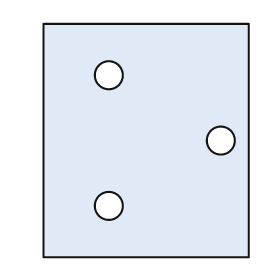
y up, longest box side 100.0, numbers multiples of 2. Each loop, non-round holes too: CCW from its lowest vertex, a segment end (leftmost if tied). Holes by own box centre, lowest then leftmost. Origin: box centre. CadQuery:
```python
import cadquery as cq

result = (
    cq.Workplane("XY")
    .moveTo(-44.0, -50.0)
    .lineTo(44.0, -50.0)
    .lineTo(44.0, 50.0)
    .lineTo(-44.0, 50.0)
    .close()
    .moveTo(-16.0, -28.0)
    .circle(6.0)
    .moveTo(32.0, 0.0)
    .circle(6.0)
    .moveTo(-16.0, 28.0)
    .circle(6.0)
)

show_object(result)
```